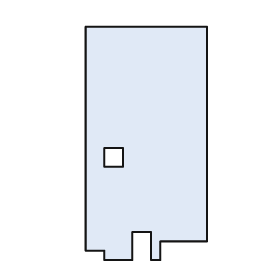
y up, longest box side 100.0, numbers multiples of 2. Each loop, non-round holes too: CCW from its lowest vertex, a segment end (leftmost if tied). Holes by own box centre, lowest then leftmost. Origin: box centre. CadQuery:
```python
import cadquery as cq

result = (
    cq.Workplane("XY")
    .moveTo(-18.0, -50.0)
    .lineTo(-6.0, -50.0)
    .lineTo(-6.0, -38.0)
    .lineTo(2.0, -38.0)
    .lineTo(2.0, -50.0)
    .lineTo(6.0, -50.0)
    .lineTo(6.0, -42.0)
    .lineTo(26.0, -42.0)
    .lineTo(26.0, 50.0)
    .lineTo(-26.0, 50.0)
    .lineTo(-26.0, -46.0)
    .lineTo(-18.0, -46.0)
    .close()
    .moveTo(-18.0, -10.0)
    .lineTo(-10.0, -10.0)
    .lineTo(-10.0, -2.0)
    .lineTo(-18.0, -2.0)
    .close()
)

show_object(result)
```